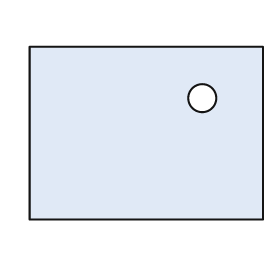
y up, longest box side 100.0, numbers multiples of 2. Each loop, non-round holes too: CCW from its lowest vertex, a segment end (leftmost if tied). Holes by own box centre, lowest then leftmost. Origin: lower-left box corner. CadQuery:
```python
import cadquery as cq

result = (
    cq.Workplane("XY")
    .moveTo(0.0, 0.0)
    .lineTo(100.0, 0.0)
    .lineTo(100.0, 74.0)
    .lineTo(0.0, 74.0)
    .close()
    .moveTo(74.0, 52.0)
    .circle(6.0)
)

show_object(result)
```